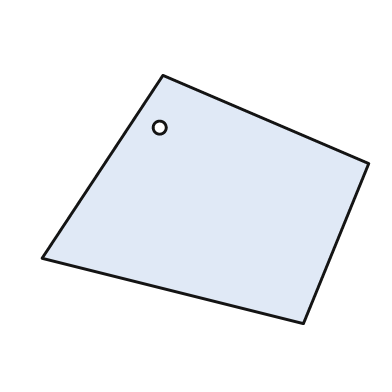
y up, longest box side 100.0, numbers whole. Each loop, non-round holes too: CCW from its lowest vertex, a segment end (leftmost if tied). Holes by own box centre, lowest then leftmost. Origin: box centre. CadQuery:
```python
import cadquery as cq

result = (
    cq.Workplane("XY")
    .moveTo(30.0, -38.0)
    .lineTo(50.0, 11.0)
    .lineTo(-13.0, 38.0)
    .lineTo(-50.0, -18.0)
    .close()
    .moveTo(-14.0, 22.0)
    .circle(2.0)
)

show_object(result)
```